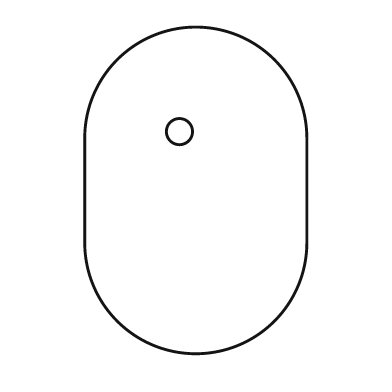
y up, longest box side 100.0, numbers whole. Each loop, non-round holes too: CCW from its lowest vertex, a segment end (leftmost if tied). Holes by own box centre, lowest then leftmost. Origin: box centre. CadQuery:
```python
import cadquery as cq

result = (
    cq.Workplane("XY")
    .moveTo(-34.0, -16.0)
    .threePointArc((0.0, -50.0), (34.0, -16.0))
    .lineTo(34.0, 16.0)
    .threePointArc((0.0, 50.0), (-34.0, 16.0))
    .close()
    .moveTo(-5.0, 18.0)
    .circle(4.0)
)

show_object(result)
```